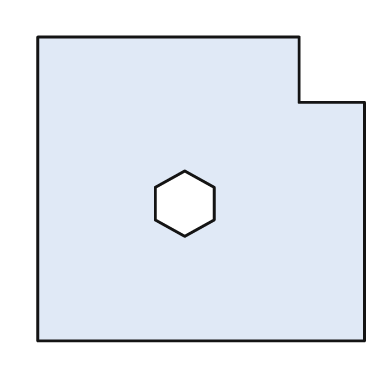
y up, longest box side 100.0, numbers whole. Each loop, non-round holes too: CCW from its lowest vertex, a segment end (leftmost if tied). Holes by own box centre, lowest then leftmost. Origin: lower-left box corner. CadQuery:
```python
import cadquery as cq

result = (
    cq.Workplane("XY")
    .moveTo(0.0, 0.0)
    .lineTo(100.0, 0.0)
    .lineTo(100.0, 73.0)
    .lineTo(80.0, 73.0)
    .lineTo(80.0, 93.0)
    .lineTo(0.0, 93.0)
    .close()
    .moveTo(45.0, 32.0)
    .lineTo(54.0, 37.0)
    .lineTo(54.0, 47.0)
    .lineTo(45.0, 52.0)
    .lineTo(36.0, 47.0)
    .lineTo(36.0, 37.0)
    .close()
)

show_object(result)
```